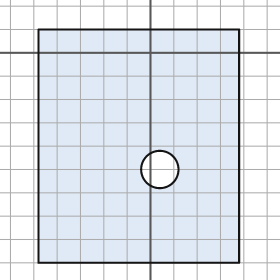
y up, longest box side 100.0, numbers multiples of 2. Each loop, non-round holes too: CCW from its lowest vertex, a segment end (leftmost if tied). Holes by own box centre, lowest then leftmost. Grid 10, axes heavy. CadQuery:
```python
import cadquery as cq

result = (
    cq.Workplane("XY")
    .moveTo(-48.0, -90.0)
    .lineTo(38.0, -90.0)
    .lineTo(38.0, 10.0)
    .lineTo(-48.0, 10.0)
    .close()
    .moveTo(4.0, -50.0)
    .circle(8.0)
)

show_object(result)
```